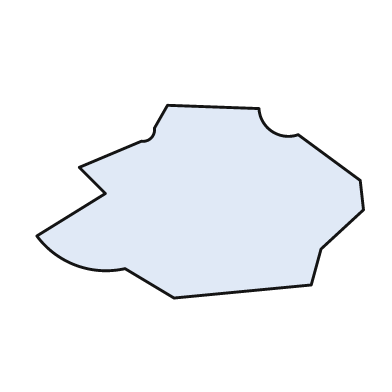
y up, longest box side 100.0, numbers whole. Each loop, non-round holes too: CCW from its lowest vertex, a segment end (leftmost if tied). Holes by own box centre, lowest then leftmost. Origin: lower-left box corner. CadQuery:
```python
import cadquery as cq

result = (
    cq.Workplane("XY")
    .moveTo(42.0, 0.0)
    .lineTo(84.0, 4.0)
    .lineTo(87.0, 15.0)
    .lineTo(100.0, 27.0)
    .lineTo(99.0, 36.0)
    .lineTo(80.0, 50.0)
    .threePointArc((72.0, 51.0), (68.0, 58.0))
    .lineTo(40.0, 59.0)
    .lineTo(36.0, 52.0)
    .threePointArc((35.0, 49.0), (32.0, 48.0))
    .lineTo(13.0, 40.0)
    .lineTo(21.0, 32.0)
    .lineTo(0.0, 19.0)
    .threePointArc((12.0, 10.0), (27.0, 9.0))
    .close()
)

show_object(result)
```